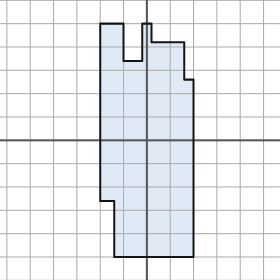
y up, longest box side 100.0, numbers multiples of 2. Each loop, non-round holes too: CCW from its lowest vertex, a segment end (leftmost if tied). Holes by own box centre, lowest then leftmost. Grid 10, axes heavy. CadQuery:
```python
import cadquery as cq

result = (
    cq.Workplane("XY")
    .moveTo(-14.0, -50.0)
    .lineTo(20.0, -50.0)
    .lineTo(20.0, 26.0)
    .lineTo(16.0, 26.0)
    .lineTo(16.0, 42.0)
    .lineTo(2.0, 42.0)
    .lineTo(2.0, 50.0)
    .lineTo(-2.0, 50.0)
    .lineTo(-2.0, 34.0)
    .lineTo(-10.0, 34.0)
    .lineTo(-10.0, 50.0)
    .lineTo(-20.0, 50.0)
    .lineTo(-20.0, -26.0)
    .lineTo(-14.0, -26.0)
    .close()
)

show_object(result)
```